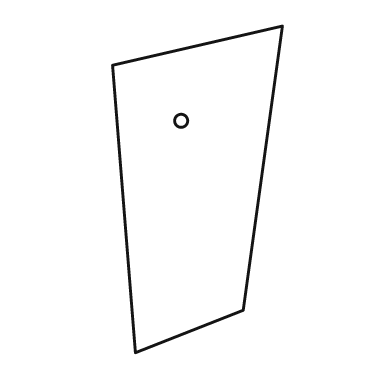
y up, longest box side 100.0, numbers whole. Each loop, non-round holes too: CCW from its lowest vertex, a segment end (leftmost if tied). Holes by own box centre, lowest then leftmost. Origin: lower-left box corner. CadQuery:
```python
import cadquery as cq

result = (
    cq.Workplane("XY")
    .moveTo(7.0, 0.0)
    .lineTo(40.0, 13.0)
    .lineTo(52.0, 100.0)
    .lineTo(0.0, 88.0)
    .close()
    .moveTo(21.0, 71.0)
    .circle(2.0)
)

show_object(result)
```